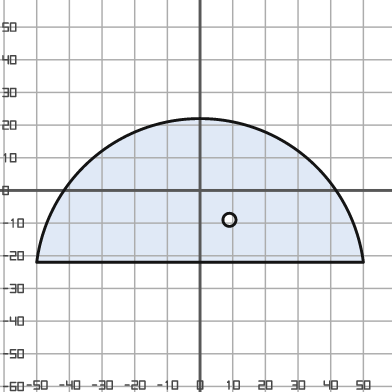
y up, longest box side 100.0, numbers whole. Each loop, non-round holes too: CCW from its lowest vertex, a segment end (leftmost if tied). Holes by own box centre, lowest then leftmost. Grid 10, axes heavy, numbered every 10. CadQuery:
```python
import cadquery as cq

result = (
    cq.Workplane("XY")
    .moveTo(-50.0, -22.0)
    .lineTo(50.0, -22.0)
    .threePointArc((0.0, 22.0), (-50.0, -22.0))
    .close()
    .moveTo(9.0, -9.0)
    .circle(2.0)
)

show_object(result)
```